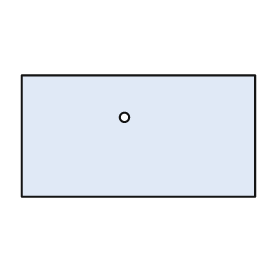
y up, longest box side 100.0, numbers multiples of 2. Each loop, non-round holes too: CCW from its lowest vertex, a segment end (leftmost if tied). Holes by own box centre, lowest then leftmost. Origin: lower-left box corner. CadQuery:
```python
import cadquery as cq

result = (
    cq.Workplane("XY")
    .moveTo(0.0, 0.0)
    .lineTo(100.0, 0.0)
    .lineTo(100.0, 52.0)
    .lineTo(0.0, 52.0)
    .close()
    .moveTo(44.0, 34.0)
    .circle(2.0)
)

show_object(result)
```